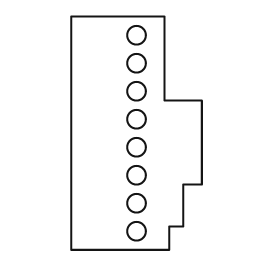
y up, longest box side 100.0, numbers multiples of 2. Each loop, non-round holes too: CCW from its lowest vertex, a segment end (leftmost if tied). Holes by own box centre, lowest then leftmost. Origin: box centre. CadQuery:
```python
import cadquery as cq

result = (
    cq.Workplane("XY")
    .moveTo(-28.0, -50.0)
    .lineTo(14.0, -50.0)
    .lineTo(14.0, -40.0)
    .lineTo(20.0, -40.0)
    .lineTo(20.0, -22.0)
    .lineTo(28.0, -22.0)
    .lineTo(28.0, 14.0)
    .lineTo(12.0, 14.0)
    .lineTo(12.0, 50.0)
    .lineTo(-28.0, 50.0)
    .close()
    .moveTo(0.0, -42.0)
    .circle(4.0)
    .moveTo(0.0, -30.0)
    .circle(4.0)
    .moveTo(0.0, -18.0)
    .circle(4.0)
    .moveTo(0.0, -6.0)
    .circle(4.0)
    .moveTo(0.0, 6.0)
    .circle(4.0)
    .moveTo(0.0, 18.0)
    .circle(4.0)
    .moveTo(0.0, 30.0)
    .circle(4.0)
    .moveTo(0.0, 42.0)
    .circle(4.0)
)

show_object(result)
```